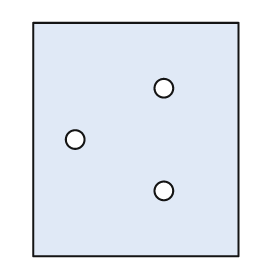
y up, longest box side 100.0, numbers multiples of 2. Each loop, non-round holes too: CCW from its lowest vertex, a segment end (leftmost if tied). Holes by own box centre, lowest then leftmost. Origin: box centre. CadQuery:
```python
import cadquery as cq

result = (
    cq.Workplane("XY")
    .moveTo(-44.0, -50.0)
    .lineTo(44.0, -50.0)
    .lineTo(44.0, 50.0)
    .lineTo(-44.0, 50.0)
    .close()
    .moveTo(12.0, -22.0)
    .circle(4.0)
    .moveTo(-26.0, 0.0)
    .circle(4.0)
    .moveTo(12.0, 22.0)
    .circle(4.0)
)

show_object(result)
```